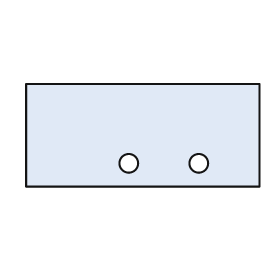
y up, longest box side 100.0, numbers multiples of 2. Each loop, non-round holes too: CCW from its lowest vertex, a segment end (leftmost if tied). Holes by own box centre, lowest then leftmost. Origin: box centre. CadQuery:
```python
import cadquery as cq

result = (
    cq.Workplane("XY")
    .moveTo(-50.0, -22.0)
    .lineTo(50.0, -22.0)
    .lineTo(50.0, 22.0)
    .lineTo(-50.0, 22.0)
    .close()
    .moveTo(-6.0, -12.0)
    .circle(4.0)
    .moveTo(24.0, -12.0)
    .circle(4.0)
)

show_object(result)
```